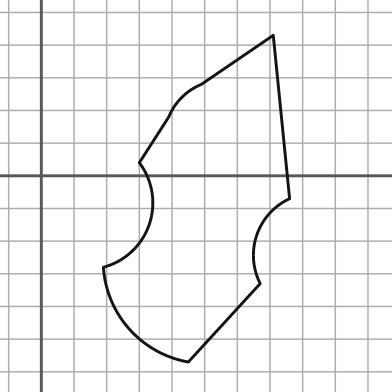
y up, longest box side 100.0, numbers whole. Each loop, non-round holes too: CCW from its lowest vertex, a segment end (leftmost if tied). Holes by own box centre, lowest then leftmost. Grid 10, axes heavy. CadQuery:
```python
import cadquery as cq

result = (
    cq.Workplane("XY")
    .moveTo(45.0, -57.0)
    .lineTo(67.0, -33.0)
    .threePointArc((66.0, -18.0), (76.0, -7.0))
    .lineTo(71.0, 43.0)
    .lineTo(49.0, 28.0)
    .threePointArc((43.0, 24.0), (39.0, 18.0))
    .lineTo(30.0, 4.0)
    .threePointArc((33.0, -15.0), (19.0, -28.0))
    .threePointArc((27.0, -47.0), (45.0, -57.0))
    .close()
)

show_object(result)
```